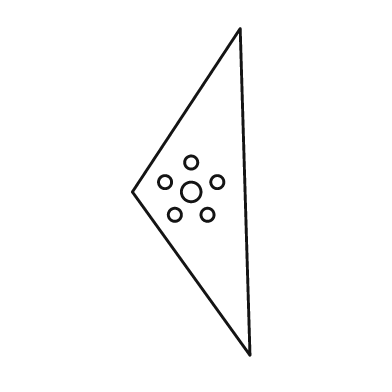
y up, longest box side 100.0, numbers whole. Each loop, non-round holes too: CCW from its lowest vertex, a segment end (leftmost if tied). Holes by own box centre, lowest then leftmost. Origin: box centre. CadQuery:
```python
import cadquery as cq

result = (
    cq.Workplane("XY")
    .moveTo(18.0, -50.0)
    .lineTo(15.0, 50.0)
    .lineTo(-18.0, 0.0)
    .close()
    .moveTo(-5.0, -7.0)
    .circle(2.0)
    .moveTo(5.0, -7.0)
    .circle(2.0)
    .moveTo(0.0, 0.0)
    .circle(3.0)
    .moveTo(-8.0, 3.0)
    .circle(2.0)
    .moveTo(8.0, 3.0)
    .circle(2.0)
    .moveTo(0.0, 9.0)
    .circle(2.0)
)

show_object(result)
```